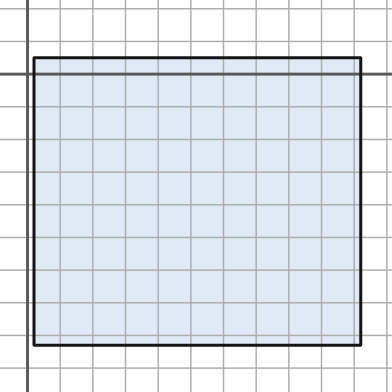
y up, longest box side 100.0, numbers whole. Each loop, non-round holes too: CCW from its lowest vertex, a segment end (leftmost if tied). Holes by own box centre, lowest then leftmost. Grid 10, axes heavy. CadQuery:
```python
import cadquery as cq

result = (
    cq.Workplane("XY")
    .moveTo(2.0, -83.0)
    .lineTo(102.0, -83.0)
    .lineTo(102.0, 5.0)
    .lineTo(2.0, 5.0)
    .close()
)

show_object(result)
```